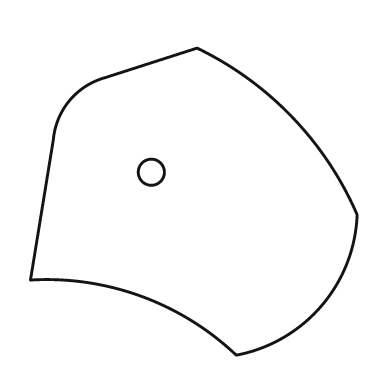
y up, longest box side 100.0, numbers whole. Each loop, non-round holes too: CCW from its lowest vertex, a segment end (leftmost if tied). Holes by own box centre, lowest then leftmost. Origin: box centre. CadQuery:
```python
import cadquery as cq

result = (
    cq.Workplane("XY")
    .moveTo(13.0, -47.0)
    .threePointArc((39.0, -32.0), (50.0, -4.0))
    .threePointArc((30.0, 26.0), (1.0, 47.0))
    .lineTo(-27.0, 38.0)
    .threePointArc((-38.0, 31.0), (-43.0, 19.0))
    .lineTo(-50.0, -24.0)
    .threePointArc((-16.0, -29.0), (13.0, -47.0))
    .close()
    .moveTo(-13.0, 9.0)
    .circle(4.0)
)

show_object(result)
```